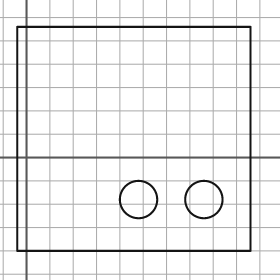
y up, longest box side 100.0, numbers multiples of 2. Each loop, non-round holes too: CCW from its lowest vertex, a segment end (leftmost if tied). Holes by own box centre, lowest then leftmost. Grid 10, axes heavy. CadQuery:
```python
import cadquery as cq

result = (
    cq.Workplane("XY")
    .moveTo(-4.0, -40.0)
    .lineTo(96.0, -40.0)
    .lineTo(96.0, 56.0)
    .lineTo(-4.0, 56.0)
    .close()
    .moveTo(48.0, -18.0)
    .circle(8.0)
    .moveTo(76.0, -18.0)
    .circle(8.0)
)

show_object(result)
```